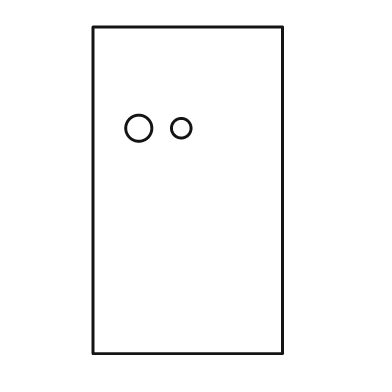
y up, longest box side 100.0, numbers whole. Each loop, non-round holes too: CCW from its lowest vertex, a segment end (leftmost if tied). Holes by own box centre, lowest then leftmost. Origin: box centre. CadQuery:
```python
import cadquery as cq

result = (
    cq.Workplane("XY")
    .moveTo(-29.0, -50.0)
    .lineTo(29.0, -50.0)
    .lineTo(29.0, 50.0)
    .lineTo(-29.0, 50.0)
    .close()
    .moveTo(-15.0, 19.0)
    .circle(4.0)
    .moveTo(-2.0, 19.0)
    .circle(3.0)
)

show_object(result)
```